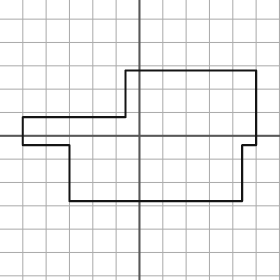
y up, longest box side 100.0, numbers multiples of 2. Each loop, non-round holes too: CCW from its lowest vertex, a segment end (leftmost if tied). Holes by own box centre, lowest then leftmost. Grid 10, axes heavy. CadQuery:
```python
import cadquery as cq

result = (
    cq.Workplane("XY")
    .moveTo(-30.0, -28.0)
    .lineTo(44.0, -28.0)
    .lineTo(44.0, -4.0)
    .lineTo(50.0, -4.0)
    .lineTo(50.0, 28.0)
    .lineTo(-6.0, 28.0)
    .lineTo(-6.0, 8.0)
    .lineTo(-50.0, 8.0)
    .lineTo(-50.0, -4.0)
    .lineTo(-30.0, -4.0)
    .close()
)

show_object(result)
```